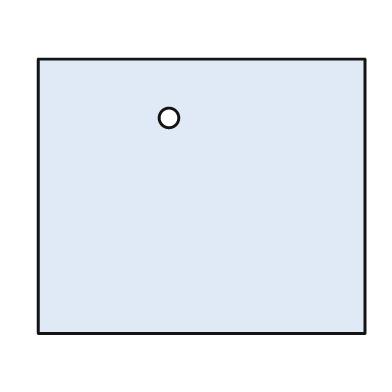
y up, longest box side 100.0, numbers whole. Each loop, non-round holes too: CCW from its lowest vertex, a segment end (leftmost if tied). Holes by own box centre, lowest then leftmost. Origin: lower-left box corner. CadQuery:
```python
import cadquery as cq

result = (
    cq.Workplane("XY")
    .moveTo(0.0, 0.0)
    .lineTo(100.0, 0.0)
    .lineTo(100.0, 84.0)
    .lineTo(0.0, 84.0)
    .close()
    .moveTo(40.0, 66.0)
    .circle(3.0)
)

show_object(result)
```